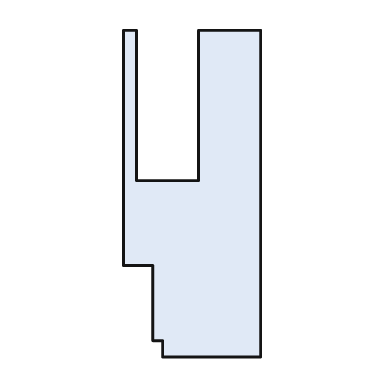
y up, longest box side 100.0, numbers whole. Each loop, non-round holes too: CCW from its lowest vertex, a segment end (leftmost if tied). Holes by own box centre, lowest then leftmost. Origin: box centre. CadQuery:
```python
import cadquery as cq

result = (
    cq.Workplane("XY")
    .moveTo(-9.0, -50.0)
    .lineTo(21.0, -50.0)
    .lineTo(21.0, 50.0)
    .lineTo(2.0, 50.0)
    .lineTo(2.0, 4.0)
    .lineTo(-17.0, 4.0)
    .lineTo(-17.0, 50.0)
    .lineTo(-21.0, 50.0)
    .lineTo(-21.0, -22.0)
    .lineTo(-12.0, -22.0)
    .lineTo(-12.0, -45.0)
    .lineTo(-9.0, -45.0)
    .close()
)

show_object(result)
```